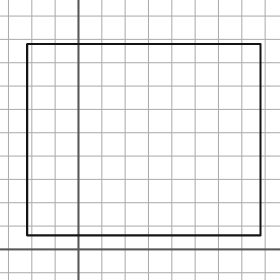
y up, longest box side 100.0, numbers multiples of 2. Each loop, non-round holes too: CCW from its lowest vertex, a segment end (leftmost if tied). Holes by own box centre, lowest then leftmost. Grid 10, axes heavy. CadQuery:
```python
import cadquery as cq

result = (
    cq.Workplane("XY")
    .moveTo(-22.0, 6.0)
    .lineTo(78.0, 6.0)
    .lineTo(78.0, 88.0)
    .lineTo(-22.0, 88.0)
    .close()
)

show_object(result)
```